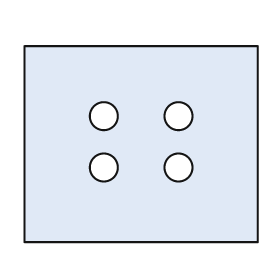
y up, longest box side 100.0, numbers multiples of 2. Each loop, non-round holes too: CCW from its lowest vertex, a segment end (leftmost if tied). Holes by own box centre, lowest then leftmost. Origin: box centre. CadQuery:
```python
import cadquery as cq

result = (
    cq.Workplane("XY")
    .moveTo(-50.0, -42.0)
    .lineTo(50.0, -42.0)
    .lineTo(50.0, 42.0)
    .lineTo(-50.0, 42.0)
    .close()
    .moveTo(-16.0, -10.0)
    .circle(6.0)
    .moveTo(16.0, -10.0)
    .circle(6.0)
    .moveTo(-16.0, 12.0)
    .circle(6.0)
    .moveTo(16.0, 12.0)
    .circle(6.0)
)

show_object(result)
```